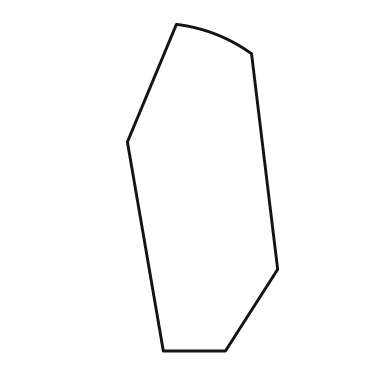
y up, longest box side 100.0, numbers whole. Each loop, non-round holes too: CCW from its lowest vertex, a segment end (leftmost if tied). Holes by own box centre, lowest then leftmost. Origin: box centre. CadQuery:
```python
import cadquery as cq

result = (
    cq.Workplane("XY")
    .moveTo(-12.0, -50.0)
    .lineTo(7.0, -50.0)
    .lineTo(23.0, -25.0)
    .lineTo(15.0, 41.0)
    .threePointArc((4.0, 47.0), (-8.0, 50.0))
    .lineTo(-23.0, 14.0)
    .close()
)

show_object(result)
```